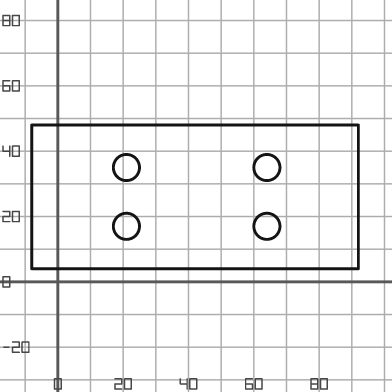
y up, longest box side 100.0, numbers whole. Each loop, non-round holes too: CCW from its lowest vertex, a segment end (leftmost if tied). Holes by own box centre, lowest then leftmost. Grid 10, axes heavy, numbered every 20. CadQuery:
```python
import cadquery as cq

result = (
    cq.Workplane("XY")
    .moveTo(-8.0, 4.0)
    .lineTo(92.0, 4.0)
    .lineTo(92.0, 48.0)
    .lineTo(-8.0, 48.0)
    .close()
    .moveTo(21.0, 17.0)
    .circle(4.0)
    .moveTo(64.0, 17.0)
    .circle(4.0)
    .moveTo(21.0, 35.0)
    .circle(4.0)
    .moveTo(64.0, 35.0)
    .circle(4.0)
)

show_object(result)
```